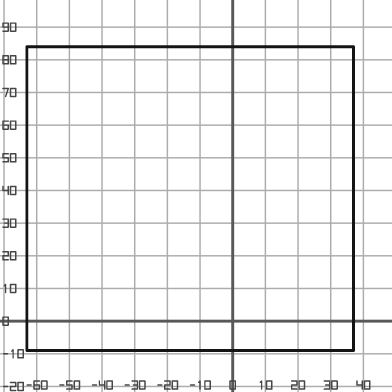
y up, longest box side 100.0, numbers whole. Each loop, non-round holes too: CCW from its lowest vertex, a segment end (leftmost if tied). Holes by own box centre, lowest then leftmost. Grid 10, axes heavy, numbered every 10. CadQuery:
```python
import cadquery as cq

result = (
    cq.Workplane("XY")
    .moveTo(-63.0, -9.0)
    .lineTo(37.0, -9.0)
    .lineTo(37.0, 84.0)
    .lineTo(-63.0, 84.0)
    .close()
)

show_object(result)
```